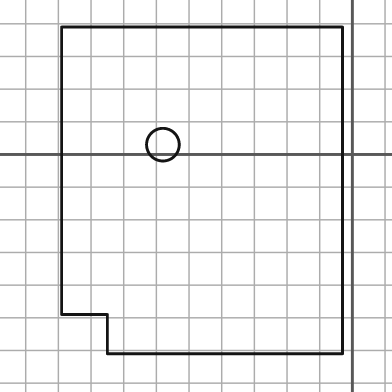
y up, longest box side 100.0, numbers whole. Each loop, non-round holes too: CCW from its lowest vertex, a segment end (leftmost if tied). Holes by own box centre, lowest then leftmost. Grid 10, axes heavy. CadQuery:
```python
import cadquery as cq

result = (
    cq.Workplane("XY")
    .moveTo(-75.0, -61.0)
    .lineTo(-3.0, -61.0)
    .lineTo(-3.0, 39.0)
    .lineTo(-89.0, 39.0)
    .lineTo(-89.0, -49.0)
    .lineTo(-75.0, -49.0)
    .close()
    .moveTo(-58.0, 3.0)
    .circle(5.0)
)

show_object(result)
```